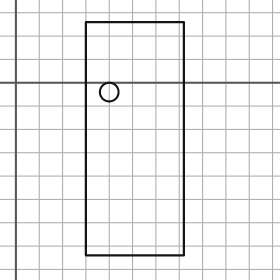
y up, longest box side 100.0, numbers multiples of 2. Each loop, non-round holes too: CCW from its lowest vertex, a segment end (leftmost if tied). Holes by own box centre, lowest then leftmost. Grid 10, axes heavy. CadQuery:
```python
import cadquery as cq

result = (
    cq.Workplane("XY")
    .moveTo(30.0, -74.0)
    .lineTo(72.0, -74.0)
    .lineTo(72.0, 26.0)
    .lineTo(30.0, 26.0)
    .close()
    .moveTo(40.0, -4.0)
    .circle(4.0)
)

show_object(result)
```